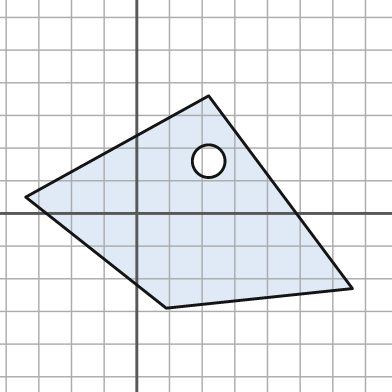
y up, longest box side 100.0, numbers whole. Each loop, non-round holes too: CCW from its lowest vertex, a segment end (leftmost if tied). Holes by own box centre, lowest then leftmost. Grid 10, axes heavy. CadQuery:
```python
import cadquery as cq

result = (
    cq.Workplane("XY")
    .moveTo(9.0, -29.0)
    .lineTo(66.0, -23.0)
    .lineTo(22.0, 36.0)
    .lineTo(-34.0, 5.0)
    .close()
    .moveTo(22.0, 16.0)
    .circle(5.0)
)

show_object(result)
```